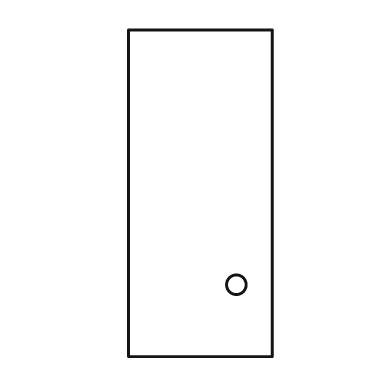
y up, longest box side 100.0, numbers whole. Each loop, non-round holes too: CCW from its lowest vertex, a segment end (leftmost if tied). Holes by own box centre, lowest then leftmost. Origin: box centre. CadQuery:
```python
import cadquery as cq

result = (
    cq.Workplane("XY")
    .moveTo(-22.0, -50.0)
    .lineTo(22.0, -50.0)
    .lineTo(22.0, 50.0)
    .lineTo(-22.0, 50.0)
    .close()
    .moveTo(11.0, -28.0)
    .circle(3.0)
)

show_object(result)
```